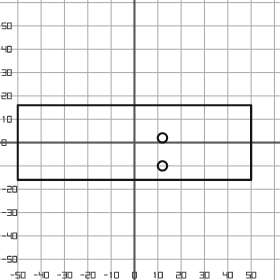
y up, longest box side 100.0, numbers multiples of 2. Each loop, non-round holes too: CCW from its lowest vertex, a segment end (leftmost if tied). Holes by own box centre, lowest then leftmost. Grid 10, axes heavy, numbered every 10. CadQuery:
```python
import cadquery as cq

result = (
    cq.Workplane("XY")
    .moveTo(-50.0, -16.0)
    .lineTo(50.0, -16.0)
    .lineTo(50.0, 16.0)
    .lineTo(-50.0, 16.0)
    .close()
    .moveTo(12.0, -10.0)
    .circle(2.0)
    .moveTo(12.0, 2.0)
    .circle(2.0)
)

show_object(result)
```